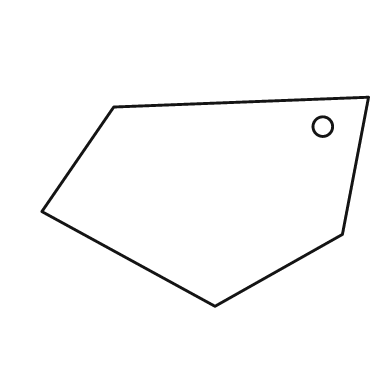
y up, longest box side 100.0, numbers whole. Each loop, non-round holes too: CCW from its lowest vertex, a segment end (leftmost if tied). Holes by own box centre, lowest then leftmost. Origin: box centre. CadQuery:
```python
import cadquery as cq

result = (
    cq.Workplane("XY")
    .moveTo(3.0, -32.0)
    .lineTo(42.0, -10.0)
    .lineTo(50.0, 32.0)
    .lineTo(-28.0, 29.0)
    .lineTo(-50.0, -3.0)
    .close()
    .moveTo(36.0, 23.0)
    .circle(3.0)
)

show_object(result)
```